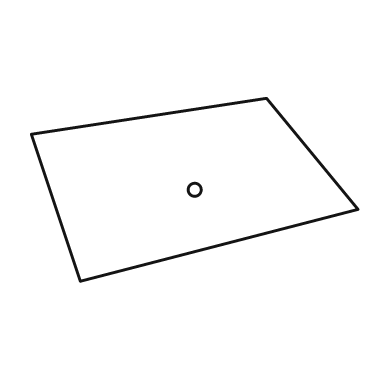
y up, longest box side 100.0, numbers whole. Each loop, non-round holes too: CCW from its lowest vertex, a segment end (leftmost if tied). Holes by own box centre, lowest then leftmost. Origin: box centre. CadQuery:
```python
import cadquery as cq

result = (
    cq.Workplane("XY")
    .moveTo(-35.0, -28.0)
    .lineTo(50.0, -6.0)
    .lineTo(22.0, 28.0)
    .lineTo(-50.0, 17.0)
    .close()
    .moveTo(0.0, 0.0)
    .circle(2.0)
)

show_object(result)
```